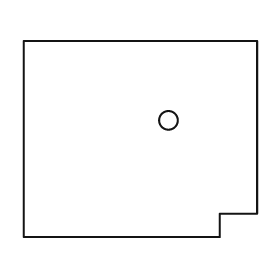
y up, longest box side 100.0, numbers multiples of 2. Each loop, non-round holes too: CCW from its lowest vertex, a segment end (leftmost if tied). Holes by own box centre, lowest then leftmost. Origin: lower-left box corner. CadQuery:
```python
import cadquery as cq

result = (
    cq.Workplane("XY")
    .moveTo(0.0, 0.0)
    .lineTo(84.0, 0.0)
    .lineTo(84.0, 10.0)
    .lineTo(100.0, 10.0)
    .lineTo(100.0, 84.0)
    .lineTo(0.0, 84.0)
    .close()
    .moveTo(62.0, 50.0)
    .circle(4.0)
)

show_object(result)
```